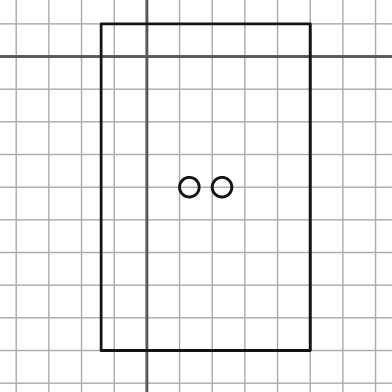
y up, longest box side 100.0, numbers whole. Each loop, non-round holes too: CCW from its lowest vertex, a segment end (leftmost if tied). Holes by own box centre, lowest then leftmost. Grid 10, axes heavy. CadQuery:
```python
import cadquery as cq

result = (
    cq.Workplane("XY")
    .moveTo(-14.0, -90.0)
    .lineTo(50.0, -90.0)
    .lineTo(50.0, 10.0)
    .lineTo(-14.0, 10.0)
    .close()
    .moveTo(13.0, -40.0)
    .circle(3.0)
    .moveTo(23.0, -40.0)
    .circle(3.0)
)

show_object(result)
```